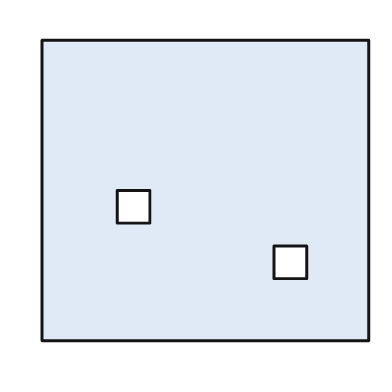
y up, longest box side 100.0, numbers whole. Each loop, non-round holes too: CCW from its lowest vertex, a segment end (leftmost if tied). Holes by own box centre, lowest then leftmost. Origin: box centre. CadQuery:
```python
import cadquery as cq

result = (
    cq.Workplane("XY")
    .moveTo(-50.0, -46.0)
    .lineTo(50.0, -46.0)
    .lineTo(50.0, 46.0)
    .lineTo(-50.0, 46.0)
    .close()
    .moveTo(21.0, -27.0)
    .lineTo(31.0, -27.0)
    .lineTo(31.0, -17.0)
    .lineTo(21.0, -17.0)
    .close()
    .moveTo(-27.0, -10.0)
    .lineTo(-17.0, -10.0)
    .lineTo(-17.0, 0.0)
    .lineTo(-27.0, 0.0)
    .close()
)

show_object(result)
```